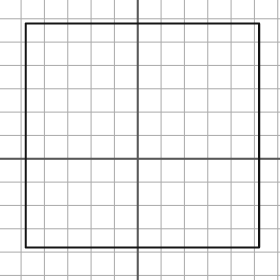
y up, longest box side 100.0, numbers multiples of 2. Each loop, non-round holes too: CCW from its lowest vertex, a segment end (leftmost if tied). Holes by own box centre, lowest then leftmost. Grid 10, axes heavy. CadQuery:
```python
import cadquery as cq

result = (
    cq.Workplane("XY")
    .moveTo(-48.0, -38.0)
    .lineTo(52.0, -38.0)
    .lineTo(52.0, 58.0)
    .lineTo(-48.0, 58.0)
    .close()
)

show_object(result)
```